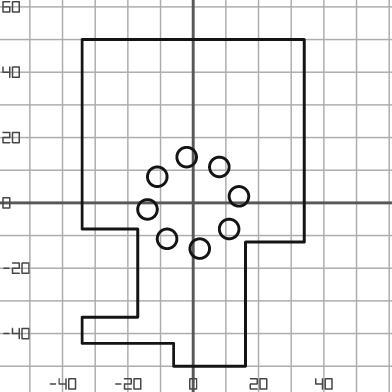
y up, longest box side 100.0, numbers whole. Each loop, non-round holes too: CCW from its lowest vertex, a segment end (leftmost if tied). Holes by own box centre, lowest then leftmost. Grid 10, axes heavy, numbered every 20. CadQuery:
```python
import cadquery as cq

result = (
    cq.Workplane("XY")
    .moveTo(-6.0, -50.0)
    .lineTo(16.0, -50.0)
    .lineTo(16.0, -12.0)
    .lineTo(34.0, -12.0)
    .lineTo(34.0, 50.0)
    .lineTo(-34.0, 50.0)
    .lineTo(-34.0, -8.0)
    .lineTo(-17.0, -8.0)
    .lineTo(-17.0, -35.0)
    .lineTo(-34.0, -35.0)
    .lineTo(-34.0, -43.0)
    .lineTo(-6.0, -43.0)
    .close()
    .moveTo(2.0, -14.0)
    .circle(3.0)
    .moveTo(-8.0, -11.0)
    .circle(3.0)
    .moveTo(11.0, -8.0)
    .circle(3.0)
    .moveTo(-14.0, -2.0)
    .circle(3.0)
    .moveTo(14.0, 2.0)
    .circle(3.0)
    .moveTo(-11.0, 8.0)
    .circle(3.0)
    .moveTo(8.0, 11.0)
    .circle(3.0)
    .moveTo(-2.0, 14.0)
    .circle(3.0)
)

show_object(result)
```